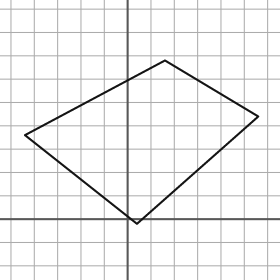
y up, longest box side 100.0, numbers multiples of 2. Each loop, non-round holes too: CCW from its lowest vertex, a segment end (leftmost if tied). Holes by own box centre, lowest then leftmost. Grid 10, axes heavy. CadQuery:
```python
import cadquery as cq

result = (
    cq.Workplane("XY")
    .moveTo(4.0, -2.0)
    .lineTo(56.0, 44.0)
    .lineTo(16.0, 68.0)
    .lineTo(-44.0, 36.0)
    .close()
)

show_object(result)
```